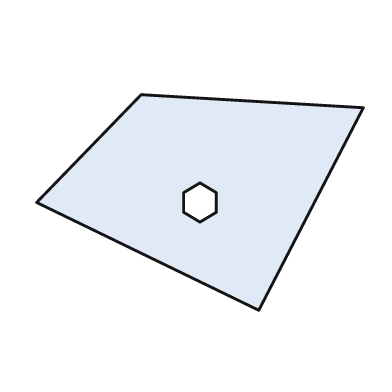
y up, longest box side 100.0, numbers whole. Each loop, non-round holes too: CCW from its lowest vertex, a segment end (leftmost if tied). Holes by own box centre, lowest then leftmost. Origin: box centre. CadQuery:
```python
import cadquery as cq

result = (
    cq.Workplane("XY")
    .moveTo(18.0, -33.0)
    .lineTo(50.0, 29.0)
    .lineTo(-18.0, 33.0)
    .lineTo(-50.0, 0.0)
    .close()
    .moveTo(0.0, -6.0)
    .lineTo(5.0, -3.0)
    .lineTo(5.0, 3.0)
    .lineTo(0.0, 6.0)
    .lineTo(-5.0, 3.0)
    .lineTo(-5.0, -3.0)
    .close()
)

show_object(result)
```